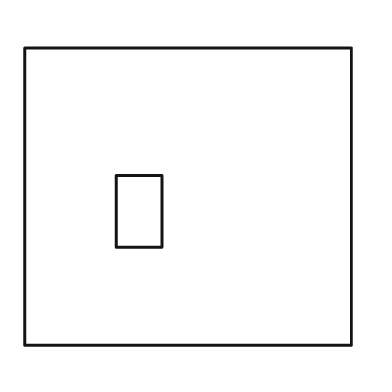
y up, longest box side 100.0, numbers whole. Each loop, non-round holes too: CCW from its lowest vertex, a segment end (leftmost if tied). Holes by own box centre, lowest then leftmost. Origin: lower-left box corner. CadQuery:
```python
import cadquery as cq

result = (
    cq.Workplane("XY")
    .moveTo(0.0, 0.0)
    .lineTo(100.0, 0.0)
    .lineTo(100.0, 91.0)
    .lineTo(0.0, 91.0)
    .close()
    .moveTo(28.0, 30.0)
    .lineTo(42.0, 30.0)
    .lineTo(42.0, 52.0)
    .lineTo(28.0, 52.0)
    .close()
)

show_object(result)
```